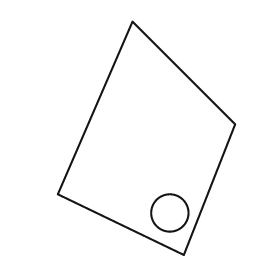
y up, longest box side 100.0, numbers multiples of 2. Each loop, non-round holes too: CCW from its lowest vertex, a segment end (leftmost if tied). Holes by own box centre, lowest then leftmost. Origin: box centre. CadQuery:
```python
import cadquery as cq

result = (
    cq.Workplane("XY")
    .moveTo(16.0, -50.0)
    .lineTo(38.0, 6.0)
    .lineTo(-6.0, 50.0)
    .lineTo(-38.0, -24.0)
    .close()
    .moveTo(10.0, -32.0)
    .circle(8.0)
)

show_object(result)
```